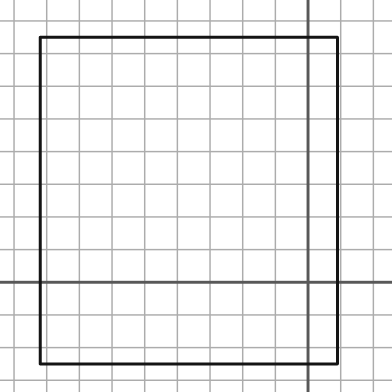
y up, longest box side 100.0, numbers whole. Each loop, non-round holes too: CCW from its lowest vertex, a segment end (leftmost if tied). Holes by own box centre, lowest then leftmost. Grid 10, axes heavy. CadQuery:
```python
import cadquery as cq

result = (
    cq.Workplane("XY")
    .moveTo(-82.0, -25.0)
    .lineTo(9.0, -25.0)
    .lineTo(9.0, 75.0)
    .lineTo(-82.0, 75.0)
    .close()
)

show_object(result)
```